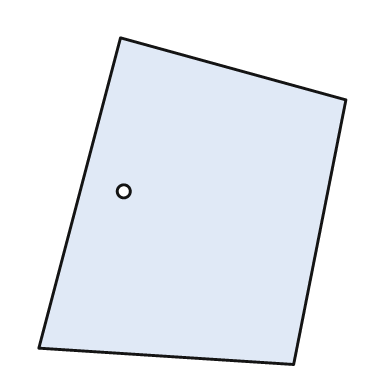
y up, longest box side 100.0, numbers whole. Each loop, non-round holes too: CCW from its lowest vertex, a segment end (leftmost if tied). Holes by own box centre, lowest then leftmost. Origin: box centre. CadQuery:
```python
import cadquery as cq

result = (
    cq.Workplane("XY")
    .moveTo(31.0, -50.0)
    .lineTo(47.0, 31.0)
    .lineTo(-22.0, 50.0)
    .lineTo(-47.0, -45.0)
    .close()
    .moveTo(-21.0, 3.0)
    .circle(2.0)
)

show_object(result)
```